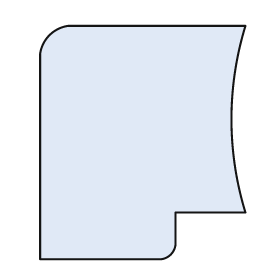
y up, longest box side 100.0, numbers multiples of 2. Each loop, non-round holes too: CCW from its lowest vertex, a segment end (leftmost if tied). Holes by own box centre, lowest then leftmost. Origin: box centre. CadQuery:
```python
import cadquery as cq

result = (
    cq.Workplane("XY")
    .moveTo(-44.0, -50.0)
    .lineTo(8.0, -50.0)
    .threePointArc((12.0, -48.0), (14.0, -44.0))
    .lineTo(14.0, -30.0)
    .lineTo(44.0, -30.0)
    .threePointArc((38.0, 10.0), (44.0, 50.0))
    .lineTo(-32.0, 50.0)
    .threePointArc((-40.0, 46.0), (-44.0, 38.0))
    .close()
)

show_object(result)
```